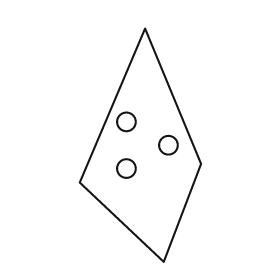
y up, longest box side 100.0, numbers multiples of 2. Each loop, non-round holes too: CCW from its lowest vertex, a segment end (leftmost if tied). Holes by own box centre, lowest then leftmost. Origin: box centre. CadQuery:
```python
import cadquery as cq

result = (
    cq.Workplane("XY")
    .moveTo(10.0, -50.0)
    .lineTo(26.0, -8.0)
    .lineTo(2.0, 50.0)
    .lineTo(-26.0, -16.0)
    .close()
    .moveTo(-6.0, -10.0)
    .circle(4.0)
    .moveTo(12.0, 0.0)
    .circle(4.0)
    .moveTo(-6.0, 10.0)
    .circle(4.0)
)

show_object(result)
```